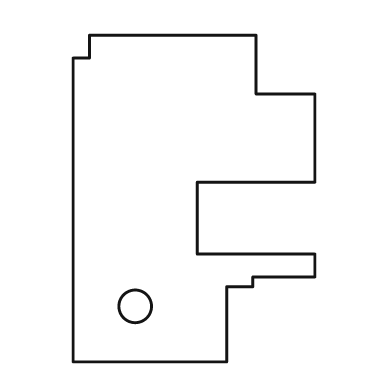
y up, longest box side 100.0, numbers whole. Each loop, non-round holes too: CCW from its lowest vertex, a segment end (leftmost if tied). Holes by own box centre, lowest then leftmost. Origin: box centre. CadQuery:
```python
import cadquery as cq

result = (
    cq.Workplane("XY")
    .moveTo(-37.0, -50.0)
    .lineTo(10.0, -50.0)
    .lineTo(10.0, -27.0)
    .lineTo(18.0, -27.0)
    .lineTo(18.0, -24.0)
    .lineTo(37.0, -24.0)
    .lineTo(37.0, -17.0)
    .lineTo(1.0, -17.0)
    .lineTo(1.0, 5.0)
    .lineTo(37.0, 5.0)
    .lineTo(37.0, 32.0)
    .lineTo(19.0, 32.0)
    .lineTo(19.0, 50.0)
    .lineTo(-32.0, 50.0)
    .lineTo(-32.0, 43.0)
    .lineTo(-37.0, 43.0)
    .close()
    .moveTo(-18.0, -33.0)
    .circle(5.0)
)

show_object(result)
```